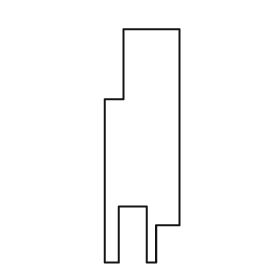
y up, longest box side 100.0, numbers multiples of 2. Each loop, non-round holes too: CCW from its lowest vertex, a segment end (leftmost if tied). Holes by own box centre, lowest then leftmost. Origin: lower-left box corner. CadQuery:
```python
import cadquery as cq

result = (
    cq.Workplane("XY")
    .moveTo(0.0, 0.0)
    .lineTo(6.0, 0.0)
    .lineTo(6.0, 24.0)
    .lineTo(18.0, 24.0)
    .lineTo(18.0, 0.0)
    .lineTo(22.0, 0.0)
    .lineTo(22.0, 16.0)
    .lineTo(32.0, 16.0)
    .lineTo(32.0, 100.0)
    .lineTo(8.0, 100.0)
    .lineTo(8.0, 70.0)
    .lineTo(0.0, 70.0)
    .close()
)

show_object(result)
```